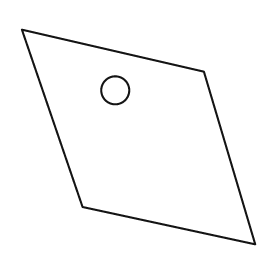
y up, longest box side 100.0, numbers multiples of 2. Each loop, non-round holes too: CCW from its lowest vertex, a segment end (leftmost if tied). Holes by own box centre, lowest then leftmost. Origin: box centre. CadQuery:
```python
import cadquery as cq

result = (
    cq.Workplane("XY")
    .moveTo(50.0, -46.0)
    .lineTo(28.0, 28.0)
    .lineTo(-50.0, 46.0)
    .lineTo(-24.0, -30.0)
    .close()
    .moveTo(-10.0, 20.0)
    .circle(6.0)
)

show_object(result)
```